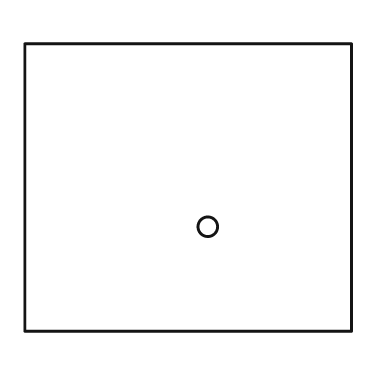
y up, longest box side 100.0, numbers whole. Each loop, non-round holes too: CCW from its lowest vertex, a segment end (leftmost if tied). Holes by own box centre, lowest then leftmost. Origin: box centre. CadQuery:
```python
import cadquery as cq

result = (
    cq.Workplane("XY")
    .moveTo(-50.0, -44.0)
    .lineTo(50.0, -44.0)
    .lineTo(50.0, 44.0)
    .lineTo(-50.0, 44.0)
    .close()
    .moveTo(6.0, -12.0)
    .circle(3.0)
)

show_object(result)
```